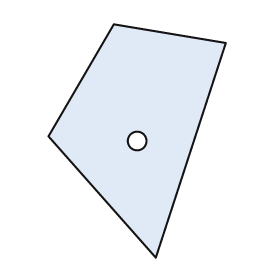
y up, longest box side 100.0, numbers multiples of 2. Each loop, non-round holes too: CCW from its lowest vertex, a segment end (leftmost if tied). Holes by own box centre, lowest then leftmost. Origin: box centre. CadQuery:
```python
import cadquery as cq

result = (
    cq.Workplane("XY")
    .moveTo(8.0, -50.0)
    .lineTo(38.0, 42.0)
    .lineTo(-10.0, 50.0)
    .lineTo(-38.0, 2.0)
    .close()
    .moveTo(0.0, 0.0)
    .circle(4.0)
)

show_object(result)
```